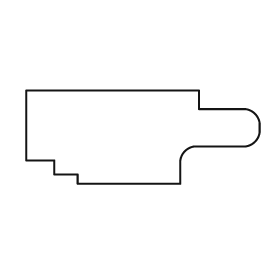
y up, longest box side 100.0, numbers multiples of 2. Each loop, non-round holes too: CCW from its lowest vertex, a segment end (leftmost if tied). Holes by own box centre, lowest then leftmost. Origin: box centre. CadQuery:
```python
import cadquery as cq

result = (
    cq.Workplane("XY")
    .moveTo(-28.0, -20.0)
    .lineTo(16.0, -20.0)
    .lineTo(16.0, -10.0)
    .threePointArc((18.0, -6.0), (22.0, -4.0))
    .lineTo(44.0, -4.0)
    .threePointArc((48.0, -2.0), (50.0, 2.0))
    .lineTo(50.0, 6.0)
    .threePointArc((48.0, 10.0), (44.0, 12.0))
    .lineTo(24.0, 12.0)
    .lineTo(24.0, 20.0)
    .lineTo(-50.0, 20.0)
    .lineTo(-50.0, -10.0)
    .lineTo(-38.0, -10.0)
    .lineTo(-38.0, -16.0)
    .lineTo(-28.0, -16.0)
    .close()
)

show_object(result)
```